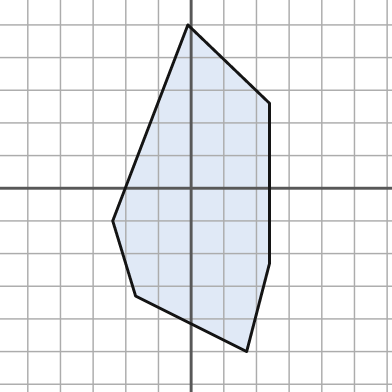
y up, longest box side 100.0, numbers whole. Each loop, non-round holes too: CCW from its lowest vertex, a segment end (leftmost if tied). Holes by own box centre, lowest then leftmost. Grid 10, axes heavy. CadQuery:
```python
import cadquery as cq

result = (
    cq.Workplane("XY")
    .moveTo(17.0, -50.0)
    .lineTo(24.0, -23.0)
    .lineTo(24.0, 26.0)
    .lineTo(-1.0, 50.0)
    .lineTo(-24.0, -10.0)
    .lineTo(-17.0, -33.0)
    .close()
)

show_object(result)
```